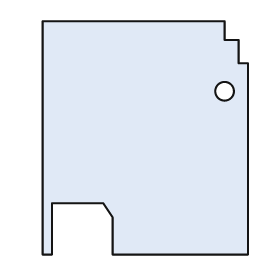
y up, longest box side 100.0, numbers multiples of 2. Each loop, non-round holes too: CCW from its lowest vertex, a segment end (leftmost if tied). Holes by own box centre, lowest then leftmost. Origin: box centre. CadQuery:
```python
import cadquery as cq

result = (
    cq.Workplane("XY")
    .moveTo(-44.0, -50.0)
    .lineTo(-40.0, -50.0)
    .lineTo(-40.0, -28.0)
    .lineTo(-18.0, -28.0)
    .lineTo(-14.0, -34.0)
    .lineTo(-14.0, -50.0)
    .lineTo(44.0, -50.0)
    .lineTo(44.0, 32.0)
    .lineTo(40.0, 32.0)
    .lineTo(40.0, 42.0)
    .lineTo(34.0, 42.0)
    .lineTo(34.0, 50.0)
    .lineTo(-44.0, 50.0)
    .close()
    .moveTo(34.0, 20.0)
    .circle(4.0)
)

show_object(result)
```